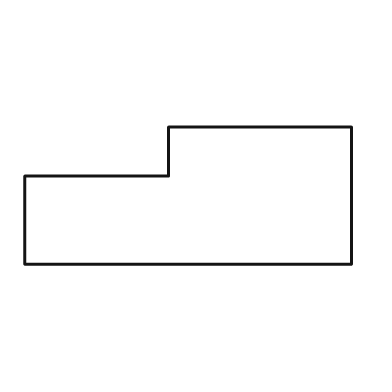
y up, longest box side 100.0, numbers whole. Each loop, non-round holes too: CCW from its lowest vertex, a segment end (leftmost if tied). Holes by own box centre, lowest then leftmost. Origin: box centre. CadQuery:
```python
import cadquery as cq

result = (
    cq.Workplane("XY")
    .moveTo(-50.0, -21.0)
    .lineTo(50.0, -21.0)
    .lineTo(50.0, 21.0)
    .lineTo(-6.0, 21.0)
    .lineTo(-6.0, 6.0)
    .lineTo(-50.0, 6.0)
    .close()
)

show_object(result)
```